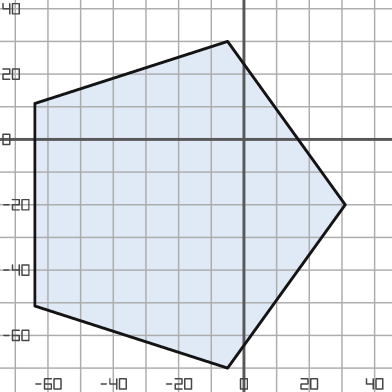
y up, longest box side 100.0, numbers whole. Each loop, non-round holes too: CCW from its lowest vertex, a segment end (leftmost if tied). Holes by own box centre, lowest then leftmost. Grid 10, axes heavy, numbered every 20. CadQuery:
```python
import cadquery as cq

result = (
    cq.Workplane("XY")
    .moveTo(-5.0, -70.0)
    .lineTo(31.0, -20.0)
    .lineTo(-5.0, 30.0)
    .lineTo(-64.0, 11.0)
    .lineTo(-64.0, -51.0)
    .close()
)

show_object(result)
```